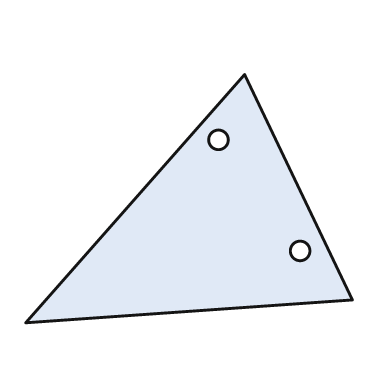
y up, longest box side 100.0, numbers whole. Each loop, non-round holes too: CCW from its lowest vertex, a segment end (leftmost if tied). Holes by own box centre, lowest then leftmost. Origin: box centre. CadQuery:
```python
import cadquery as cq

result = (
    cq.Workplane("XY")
    .moveTo(-50.0, -38.0)
    .lineTo(50.0, -31.0)
    .lineTo(17.0, 38.0)
    .close()
    .moveTo(34.0, -16.0)
    .circle(3.0)
    .moveTo(9.0, 18.0)
    .circle(3.0)
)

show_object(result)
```